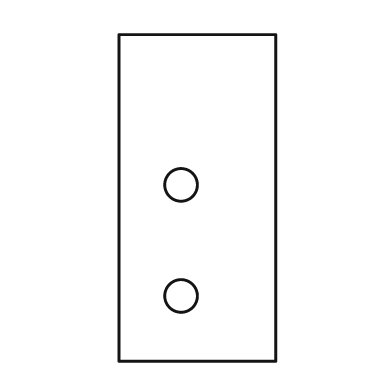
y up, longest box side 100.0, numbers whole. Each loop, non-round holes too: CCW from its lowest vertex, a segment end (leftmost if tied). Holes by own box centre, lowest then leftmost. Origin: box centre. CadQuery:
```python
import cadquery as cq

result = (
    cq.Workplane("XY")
    .moveTo(-24.0, -50.0)
    .lineTo(24.0, -50.0)
    .lineTo(24.0, 50.0)
    .lineTo(-24.0, 50.0)
    .close()
    .moveTo(-5.0, -30.0)
    .circle(5.0)
    .moveTo(-5.0, 4.0)
    .circle(5.0)
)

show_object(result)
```